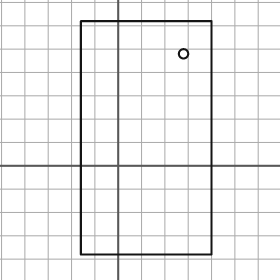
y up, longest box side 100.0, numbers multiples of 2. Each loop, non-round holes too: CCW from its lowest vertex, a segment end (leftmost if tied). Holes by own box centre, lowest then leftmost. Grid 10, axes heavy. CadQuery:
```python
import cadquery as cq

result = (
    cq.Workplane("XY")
    .moveTo(-16.0, -38.0)
    .lineTo(40.0, -38.0)
    .lineTo(40.0, 62.0)
    .lineTo(-16.0, 62.0)
    .close()
    .moveTo(28.0, 48.0)
    .circle(2.0)
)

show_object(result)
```